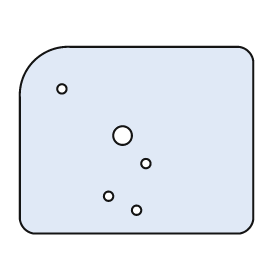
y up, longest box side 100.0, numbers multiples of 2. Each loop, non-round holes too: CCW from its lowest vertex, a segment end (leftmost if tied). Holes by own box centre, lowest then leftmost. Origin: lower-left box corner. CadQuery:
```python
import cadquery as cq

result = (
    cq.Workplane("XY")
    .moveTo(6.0, 0.0)
    .lineTo(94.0, 0.0)
    .threePointArc((98.0, 2.0), (100.0, 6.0))
    .lineTo(100.0, 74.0)
    .threePointArc((98.0, 78.0), (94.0, 80.0))
    .lineTo(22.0, 80.0)
    .threePointArc((6.0, 74.0), (0.0, 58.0))
    .lineTo(0.0, 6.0)
    .threePointArc((2.0, 2.0), (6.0, 0.0))
    .close()
    .moveTo(50.0, 10.0)
    .circle(2.0)
    .moveTo(38.0, 16.0)
    .circle(2.0)
    .moveTo(54.0, 30.0)
    .circle(2.0)
    .moveTo(44.0, 42.0)
    .circle(4.0)
    .moveTo(18.0, 62.0)
    .circle(2.0)
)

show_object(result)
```